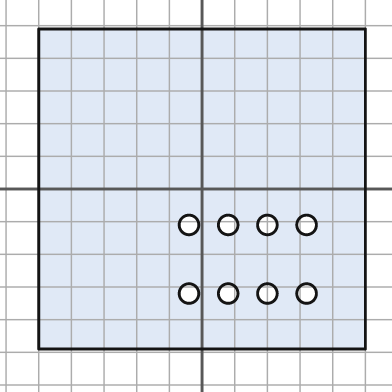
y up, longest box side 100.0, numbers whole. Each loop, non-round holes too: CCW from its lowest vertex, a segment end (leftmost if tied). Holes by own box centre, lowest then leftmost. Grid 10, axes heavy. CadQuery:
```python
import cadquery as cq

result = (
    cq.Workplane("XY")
    .moveTo(-50.0, -49.0)
    .lineTo(50.0, -49.0)
    .lineTo(50.0, 49.0)
    .lineTo(-50.0, 49.0)
    .close()
    .moveTo(-4.0, -32.0)
    .circle(3.0)
    .moveTo(8.0, -32.0)
    .circle(3.0)
    .moveTo(20.0, -32.0)
    .circle(3.0)
    .moveTo(32.0, -32.0)
    .circle(3.0)
    .moveTo(-4.0, -11.0)
    .circle(3.0)
    .moveTo(8.0, -11.0)
    .circle(3.0)
    .moveTo(20.0, -11.0)
    .circle(3.0)
    .moveTo(32.0, -11.0)
    .circle(3.0)
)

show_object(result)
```